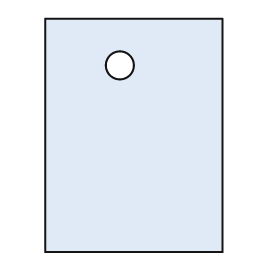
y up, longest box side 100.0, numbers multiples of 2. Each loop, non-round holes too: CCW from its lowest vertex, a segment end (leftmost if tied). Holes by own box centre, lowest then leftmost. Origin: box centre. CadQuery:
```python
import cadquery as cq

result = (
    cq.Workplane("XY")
    .moveTo(-38.0, -50.0)
    .lineTo(38.0, -50.0)
    .lineTo(38.0, 50.0)
    .lineTo(-38.0, 50.0)
    .close()
    .moveTo(-6.0, 30.0)
    .circle(6.0)
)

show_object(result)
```